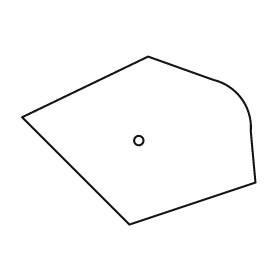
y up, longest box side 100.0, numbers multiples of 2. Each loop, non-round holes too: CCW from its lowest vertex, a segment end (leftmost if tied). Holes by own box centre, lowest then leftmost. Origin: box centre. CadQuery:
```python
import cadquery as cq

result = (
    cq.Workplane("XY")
    .moveTo(-4.0, -36.0)
    .lineTo(50.0, -18.0)
    .lineTo(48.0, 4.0)
    .threePointArc((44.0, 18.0), (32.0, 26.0))
    .lineTo(4.0, 36.0)
    .lineTo(-50.0, 10.0)
    .close()
    .moveTo(0.0, 0.0)
    .circle(2.0)
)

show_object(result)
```